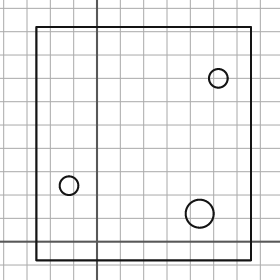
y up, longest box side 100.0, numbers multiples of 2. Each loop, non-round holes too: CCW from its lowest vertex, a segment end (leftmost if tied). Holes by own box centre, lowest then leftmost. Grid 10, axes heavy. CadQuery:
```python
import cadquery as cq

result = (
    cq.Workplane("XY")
    .moveTo(-26.0, -8.0)
    .lineTo(66.0, -8.0)
    .lineTo(66.0, 92.0)
    .lineTo(-26.0, 92.0)
    .close()
    .moveTo(44.0, 12.0)
    .circle(6.0)
    .moveTo(-12.0, 24.0)
    .circle(4.0)
    .moveTo(52.0, 70.0)
    .circle(4.0)
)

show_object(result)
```